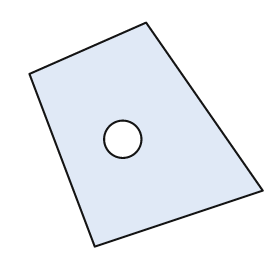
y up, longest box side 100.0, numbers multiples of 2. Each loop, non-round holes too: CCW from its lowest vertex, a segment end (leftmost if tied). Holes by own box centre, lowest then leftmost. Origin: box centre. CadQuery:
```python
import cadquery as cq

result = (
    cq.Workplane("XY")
    .moveTo(-22.0, -48.0)
    .lineTo(50.0, -24.0)
    .lineTo(0.0, 48.0)
    .lineTo(-50.0, 26.0)
    .close()
    .moveTo(-10.0, -2.0)
    .circle(8.0)
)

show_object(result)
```